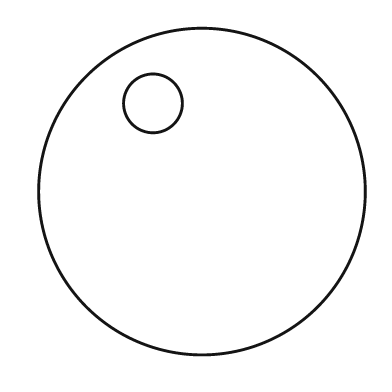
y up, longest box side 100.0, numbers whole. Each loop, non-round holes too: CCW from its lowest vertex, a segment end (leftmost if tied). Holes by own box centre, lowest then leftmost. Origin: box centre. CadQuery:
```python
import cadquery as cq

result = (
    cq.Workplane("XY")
    .moveTo(0.0, 0.0)
    .circle(50.0)
    .moveTo(-15.0, 27.0)
    .circle(9.0)
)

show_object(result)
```